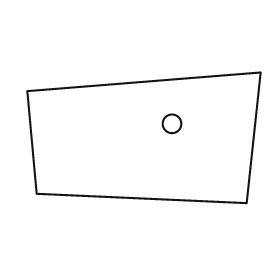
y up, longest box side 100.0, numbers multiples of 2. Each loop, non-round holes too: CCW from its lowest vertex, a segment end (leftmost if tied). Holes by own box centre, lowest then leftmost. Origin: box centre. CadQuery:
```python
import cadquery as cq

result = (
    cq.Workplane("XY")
    .moveTo(44.0, -28.0)
    .lineTo(50.0, 28.0)
    .lineTo(-50.0, 20.0)
    .lineTo(-46.0, -24.0)
    .close()
    .moveTo(12.0, 6.0)
    .circle(4.0)
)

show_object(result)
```